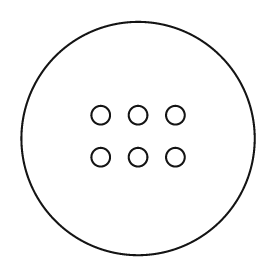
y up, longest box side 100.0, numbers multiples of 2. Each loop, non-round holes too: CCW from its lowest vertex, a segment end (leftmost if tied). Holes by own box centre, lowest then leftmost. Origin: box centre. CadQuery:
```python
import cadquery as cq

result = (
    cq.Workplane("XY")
    .moveTo(0.0, 0.0)
    .circle(50.0)
    .moveTo(-16.0, -8.0)
    .circle(4.0)
    .moveTo(0.0, -8.0)
    .circle(4.0)
    .moveTo(16.0, -8.0)
    .circle(4.0)
    .moveTo(-16.0, 10.0)
    .circle(4.0)
    .moveTo(0.0, 10.0)
    .circle(4.0)
    .moveTo(16.0, 10.0)
    .circle(4.0)
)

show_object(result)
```